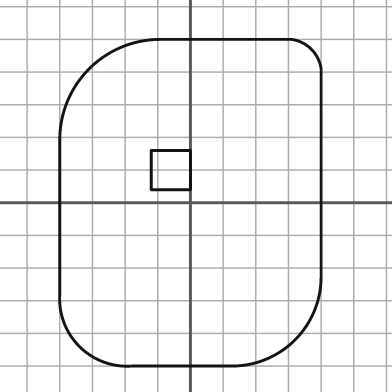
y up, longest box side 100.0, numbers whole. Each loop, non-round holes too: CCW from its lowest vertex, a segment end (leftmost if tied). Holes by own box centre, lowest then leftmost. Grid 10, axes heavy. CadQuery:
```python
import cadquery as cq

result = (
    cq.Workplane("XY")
    .moveTo(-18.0, -50.0)
    .lineTo(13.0, -50.0)
    .threePointArc((32.0, -42.0), (40.0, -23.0))
    .lineTo(40.0, 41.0)
    .threePointArc((37.0, 47.0), (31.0, 50.0))
    .lineTo(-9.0, 50.0)
    .threePointArc((-31.0, 41.0), (-40.0, 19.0))
    .lineTo(-40.0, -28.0)
    .threePointArc((-34.0, -44.0), (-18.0, -50.0))
    .close()
    .moveTo(-12.0, 4.0)
    .lineTo(0.0, 4.0)
    .lineTo(0.0, 16.0)
    .lineTo(-12.0, 16.0)
    .close()
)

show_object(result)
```